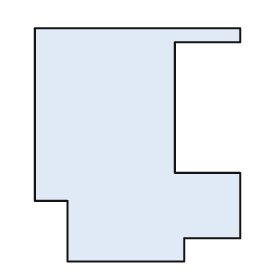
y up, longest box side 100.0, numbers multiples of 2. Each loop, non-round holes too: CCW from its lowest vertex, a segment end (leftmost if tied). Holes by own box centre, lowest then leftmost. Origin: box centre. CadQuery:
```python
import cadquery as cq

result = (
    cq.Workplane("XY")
    .moveTo(-30.0, -50.0)
    .lineTo(20.0, -50.0)
    .lineTo(20.0, -40.0)
    .lineTo(44.0, -40.0)
    .lineTo(44.0, -12.0)
    .lineTo(16.0, -12.0)
    .lineTo(16.0, 44.0)
    .lineTo(44.0, 44.0)
    .lineTo(44.0, 50.0)
    .lineTo(-44.0, 50.0)
    .lineTo(-44.0, -24.0)
    .lineTo(-30.0, -24.0)
    .close()
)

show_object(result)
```